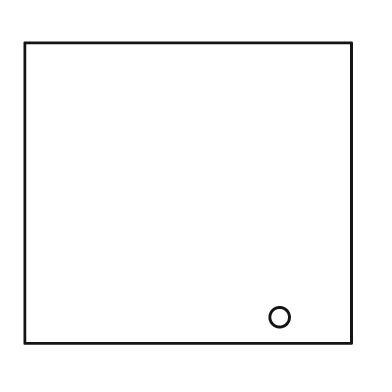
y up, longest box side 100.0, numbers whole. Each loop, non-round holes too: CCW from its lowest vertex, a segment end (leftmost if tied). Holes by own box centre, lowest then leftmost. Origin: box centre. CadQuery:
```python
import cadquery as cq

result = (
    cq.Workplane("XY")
    .moveTo(-50.0, -46.0)
    .lineTo(50.0, -46.0)
    .lineTo(50.0, 46.0)
    .lineTo(-50.0, 46.0)
    .close()
    .moveTo(28.0, -38.0)
    .circle(3.0)
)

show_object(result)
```